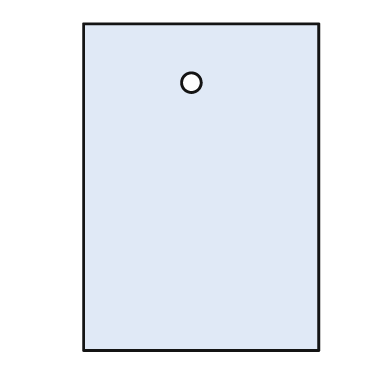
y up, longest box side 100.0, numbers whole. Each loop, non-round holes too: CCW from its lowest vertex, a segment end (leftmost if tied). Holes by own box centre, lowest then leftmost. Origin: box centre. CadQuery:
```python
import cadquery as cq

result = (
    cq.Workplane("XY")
    .moveTo(-36.0, -50.0)
    .lineTo(36.0, -50.0)
    .lineTo(36.0, 50.0)
    .lineTo(-36.0, 50.0)
    .close()
    .moveTo(-3.0, 32.0)
    .circle(3.0)
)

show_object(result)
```